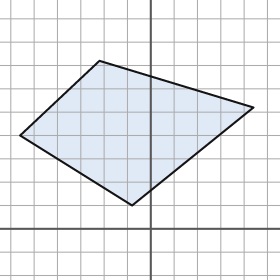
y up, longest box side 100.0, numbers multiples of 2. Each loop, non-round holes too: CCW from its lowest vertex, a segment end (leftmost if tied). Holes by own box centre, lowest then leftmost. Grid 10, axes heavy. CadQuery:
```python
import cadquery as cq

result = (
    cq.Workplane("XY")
    .moveTo(-8.0, 10.0)
    .lineTo(44.0, 52.0)
    .lineTo(-22.0, 72.0)
    .lineTo(-56.0, 40.0)
    .close()
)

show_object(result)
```